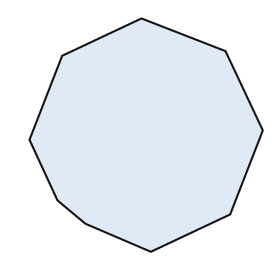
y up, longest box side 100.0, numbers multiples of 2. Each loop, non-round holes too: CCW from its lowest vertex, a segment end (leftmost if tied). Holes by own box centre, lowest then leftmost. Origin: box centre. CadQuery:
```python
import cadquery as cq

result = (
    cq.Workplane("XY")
    .moveTo(2.0, -50.0)
    .lineTo(36.0, -34.0)
    .lineTo(50.0, 2.0)
    .lineTo(34.0, 36.0)
    .lineTo(-2.0, 50.0)
    .lineTo(-36.0, 34.0)
    .lineTo(-50.0, -2.0)
    .lineTo(-38.0, -28.0)
    .lineTo(-26.0, -38.0)
    .close()
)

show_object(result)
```